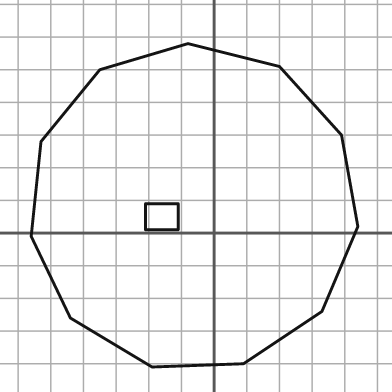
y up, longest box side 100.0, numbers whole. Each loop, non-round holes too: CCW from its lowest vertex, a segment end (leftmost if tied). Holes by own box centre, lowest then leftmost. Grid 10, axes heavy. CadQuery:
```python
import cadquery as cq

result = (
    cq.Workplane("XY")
    .moveTo(-19.0, -41.0)
    .lineTo(9.0, -40.0)
    .lineTo(33.0, -24.0)
    .lineTo(44.0, 2.0)
    .lineTo(39.0, 30.0)
    .lineTo(20.0, 51.0)
    .lineTo(-8.0, 58.0)
    .lineTo(-35.0, 50.0)
    .lineTo(-53.0, 28.0)
    .lineTo(-56.0, -1.0)
    .lineTo(-44.0, -26.0)
    .close()
    .moveTo(-21.0, 1.0)
    .lineTo(-11.0, 1.0)
    .lineTo(-11.0, 9.0)
    .lineTo(-21.0, 9.0)
    .close()
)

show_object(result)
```